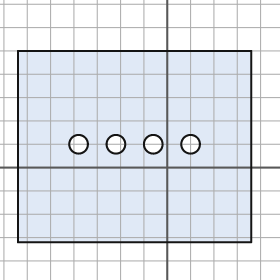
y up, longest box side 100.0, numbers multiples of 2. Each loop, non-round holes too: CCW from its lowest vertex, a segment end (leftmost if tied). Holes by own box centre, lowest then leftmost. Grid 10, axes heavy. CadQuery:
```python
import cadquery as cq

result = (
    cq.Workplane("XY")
    .moveTo(-64.0, -32.0)
    .lineTo(36.0, -32.0)
    .lineTo(36.0, 50.0)
    .lineTo(-64.0, 50.0)
    .close()
    .moveTo(-38.0, 10.0)
    .circle(4.0)
    .moveTo(-22.0, 10.0)
    .circle(4.0)
    .moveTo(-6.0, 10.0)
    .circle(4.0)
    .moveTo(10.0, 10.0)
    .circle(4.0)
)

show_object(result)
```